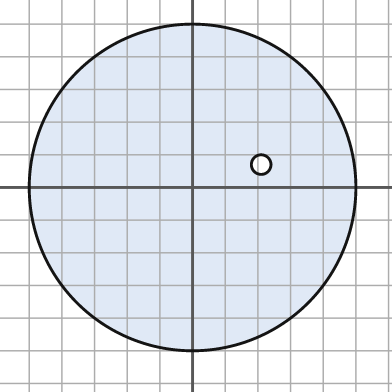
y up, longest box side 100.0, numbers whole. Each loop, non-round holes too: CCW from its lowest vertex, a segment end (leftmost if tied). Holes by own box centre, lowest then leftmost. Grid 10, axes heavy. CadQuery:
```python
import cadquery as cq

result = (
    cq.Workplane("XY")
    .moveTo(0.0, 0.0)
    .circle(50.0)
    .moveTo(21.0, 7.0)
    .circle(3.0)
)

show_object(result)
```